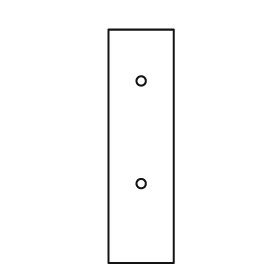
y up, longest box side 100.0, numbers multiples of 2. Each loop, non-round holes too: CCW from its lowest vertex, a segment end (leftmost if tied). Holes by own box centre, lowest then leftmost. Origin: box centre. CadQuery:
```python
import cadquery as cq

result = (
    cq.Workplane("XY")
    .moveTo(-14.0, -50.0)
    .lineTo(14.0, -50.0)
    .lineTo(14.0, 50.0)
    .lineTo(-14.0, 50.0)
    .close()
    .moveTo(0.0, -16.0)
    .circle(2.0)
    .moveTo(0.0, 28.0)
    .circle(2.0)
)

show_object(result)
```